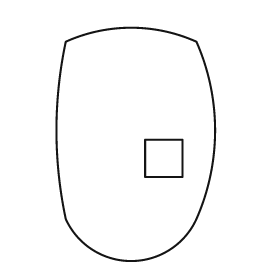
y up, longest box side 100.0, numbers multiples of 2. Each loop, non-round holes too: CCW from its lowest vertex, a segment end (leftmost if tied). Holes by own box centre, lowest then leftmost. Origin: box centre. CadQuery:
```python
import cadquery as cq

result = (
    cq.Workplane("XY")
    .moveTo(-30.0, -32.0)
    .threePointArc((-2.0, -50.0), (26.0, -32.0))
    .threePointArc((34.0, 6.0), (26.0, 44.0))
    .threePointArc((-2.0, 50.0), (-30.0, 44.0))
    .threePointArc((-34.0, 6.0), (-30.0, -32.0))
    .close()
    .moveTo(4.0, -14.0)
    .lineTo(20.0, -14.0)
    .lineTo(20.0, 2.0)
    .lineTo(4.0, 2.0)
    .close()
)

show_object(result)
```